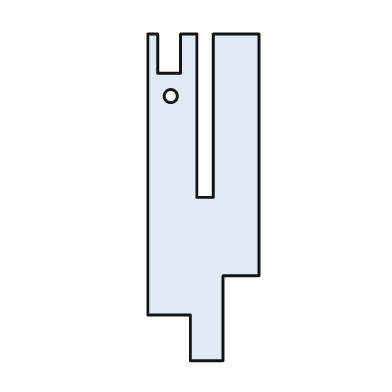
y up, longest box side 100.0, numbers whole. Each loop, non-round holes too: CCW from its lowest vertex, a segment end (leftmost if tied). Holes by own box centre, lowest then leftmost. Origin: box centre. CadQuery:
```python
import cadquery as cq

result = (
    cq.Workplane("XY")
    .moveTo(-4.0, -50.0)
    .lineTo(6.0, -50.0)
    .lineTo(6.0, -24.0)
    .lineTo(17.0, -24.0)
    .lineTo(17.0, 50.0)
    .lineTo(3.0, 50.0)
    .lineTo(3.0, 0.0)
    .lineTo(-2.0, 0.0)
    .lineTo(-2.0, 50.0)
    .lineTo(-7.0, 50.0)
    .lineTo(-7.0, 38.0)
    .lineTo(-14.0, 38.0)
    .lineTo(-14.0, 50.0)
    .lineTo(-17.0, 50.0)
    .lineTo(-17.0, -36.0)
    .lineTo(-4.0, -36.0)
    .close()
    .moveTo(-10.0, 31.0)
    .circle(2.0)
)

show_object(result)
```